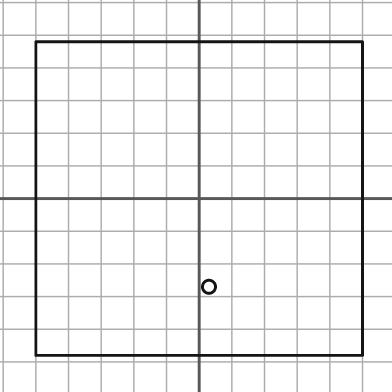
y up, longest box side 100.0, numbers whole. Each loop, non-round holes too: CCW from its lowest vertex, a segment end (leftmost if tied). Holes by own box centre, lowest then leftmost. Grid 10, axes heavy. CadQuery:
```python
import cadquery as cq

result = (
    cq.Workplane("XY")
    .moveTo(-50.0, -48.0)
    .lineTo(50.0, -48.0)
    .lineTo(50.0, 48.0)
    .lineTo(-50.0, 48.0)
    .close()
    .moveTo(3.0, -27.0)
    .circle(2.0)
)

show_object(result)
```